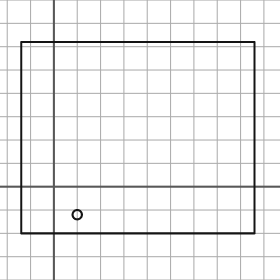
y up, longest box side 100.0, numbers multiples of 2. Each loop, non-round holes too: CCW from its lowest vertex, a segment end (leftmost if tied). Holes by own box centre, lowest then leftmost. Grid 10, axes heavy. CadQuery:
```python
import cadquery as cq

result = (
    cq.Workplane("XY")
    .moveTo(-14.0, -20.0)
    .lineTo(86.0, -20.0)
    .lineTo(86.0, 62.0)
    .lineTo(-14.0, 62.0)
    .close()
    .moveTo(10.0, -12.0)
    .circle(2.0)
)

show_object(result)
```